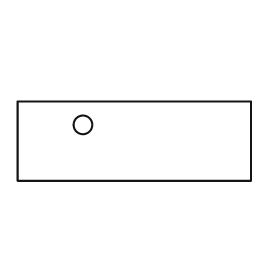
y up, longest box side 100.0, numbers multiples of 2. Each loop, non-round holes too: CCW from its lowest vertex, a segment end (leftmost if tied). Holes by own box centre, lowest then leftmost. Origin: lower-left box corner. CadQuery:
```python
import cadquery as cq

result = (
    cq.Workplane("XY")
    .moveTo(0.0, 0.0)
    .lineTo(100.0, 0.0)
    .lineTo(100.0, 34.0)
    .lineTo(0.0, 34.0)
    .close()
    .moveTo(28.0, 24.0)
    .circle(4.0)
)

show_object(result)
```